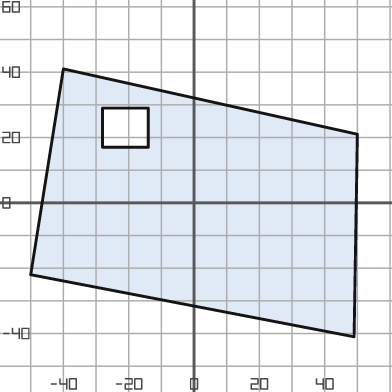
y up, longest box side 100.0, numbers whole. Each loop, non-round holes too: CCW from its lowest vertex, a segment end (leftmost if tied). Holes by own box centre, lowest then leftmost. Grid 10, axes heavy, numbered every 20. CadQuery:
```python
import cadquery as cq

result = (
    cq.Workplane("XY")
    .moveTo(49.0, -41.0)
    .lineTo(50.0, 21.0)
    .lineTo(-40.0, 41.0)
    .lineTo(-50.0, -22.0)
    .close()
    .moveTo(-28.0, 17.0)
    .lineTo(-14.0, 17.0)
    .lineTo(-14.0, 29.0)
    .lineTo(-28.0, 29.0)
    .close()
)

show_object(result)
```